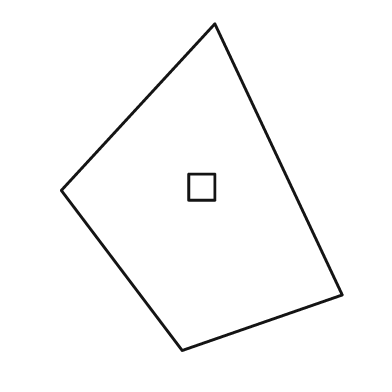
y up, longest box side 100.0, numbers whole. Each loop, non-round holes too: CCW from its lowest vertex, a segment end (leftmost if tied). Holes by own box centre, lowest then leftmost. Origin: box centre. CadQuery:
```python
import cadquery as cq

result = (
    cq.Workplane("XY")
    .moveTo(-6.0, -50.0)
    .lineTo(43.0, -33.0)
    .lineTo(4.0, 50.0)
    .lineTo(-43.0, -1.0)
    .close()
    .moveTo(-4.0, -4.0)
    .lineTo(4.0, -4.0)
    .lineTo(4.0, 4.0)
    .lineTo(-4.0, 4.0)
    .close()
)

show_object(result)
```